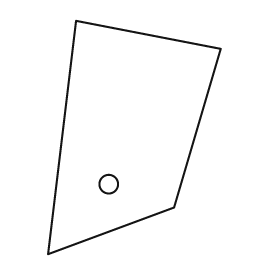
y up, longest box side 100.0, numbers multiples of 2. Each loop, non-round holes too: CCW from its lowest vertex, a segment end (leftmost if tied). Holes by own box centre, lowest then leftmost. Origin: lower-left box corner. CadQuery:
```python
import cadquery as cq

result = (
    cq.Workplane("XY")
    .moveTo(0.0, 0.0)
    .lineTo(54.0, 20.0)
    .lineTo(74.0, 88.0)
    .lineTo(12.0, 100.0)
    .close()
    .moveTo(26.0, 30.0)
    .circle(4.0)
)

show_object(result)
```